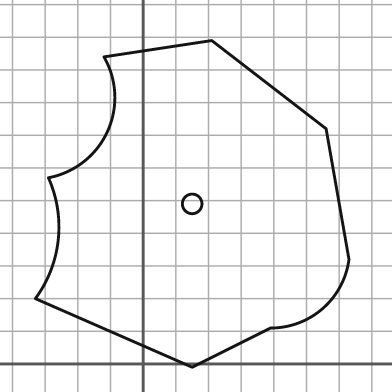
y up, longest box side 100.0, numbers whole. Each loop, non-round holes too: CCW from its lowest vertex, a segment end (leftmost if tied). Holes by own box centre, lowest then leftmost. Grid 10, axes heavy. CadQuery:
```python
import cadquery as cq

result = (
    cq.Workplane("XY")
    .moveTo(15.0, -1.0)
    .lineTo(39.0, 11.0)
    .threePointArc((55.0, 17.0), (63.0, 32.0))
    .lineTo(56.0, 72.0)
    .lineTo(21.0, 99.0)
    .lineTo(-12.0, 94.0)
    .threePointArc((-11.0, 71.0), (-29.0, 57.0))
    .threePointArc((-26.0, 38.0), (-33.0, 20.0))
    .close()
    .moveTo(15.0, 49.0)
    .circle(3.0)
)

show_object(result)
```